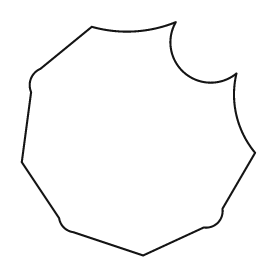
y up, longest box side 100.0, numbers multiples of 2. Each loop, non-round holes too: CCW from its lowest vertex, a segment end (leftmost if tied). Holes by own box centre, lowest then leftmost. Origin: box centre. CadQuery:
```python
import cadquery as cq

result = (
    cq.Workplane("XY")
    .moveTo(2.0, -50.0)
    .lineTo(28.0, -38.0)
    .threePointArc((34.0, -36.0), (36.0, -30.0))
    .lineTo(50.0, -6.0)
    .threePointArc((42.0, 10.0), (42.0, 28.0))
    .threePointArc((20.0, 28.0), (16.0, 50.0))
    .threePointArc((-2.0, 46.0), (-20.0, 48.0))
    .lineTo(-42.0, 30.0)
    .threePointArc((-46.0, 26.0), (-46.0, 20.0))
    .lineTo(-50.0, -10.0)
    .lineTo(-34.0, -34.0)
    .threePointArc((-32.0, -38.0), (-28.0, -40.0))
    .close()
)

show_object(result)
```